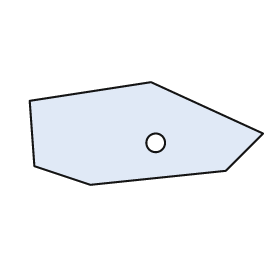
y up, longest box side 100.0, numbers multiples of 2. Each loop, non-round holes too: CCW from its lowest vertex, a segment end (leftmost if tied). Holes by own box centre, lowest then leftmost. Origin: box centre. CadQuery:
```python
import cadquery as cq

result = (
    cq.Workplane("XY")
    .moveTo(-24.0, -22.0)
    .lineTo(34.0, -16.0)
    .lineTo(50.0, 0.0)
    .lineTo(2.0, 22.0)
    .lineTo(-50.0, 14.0)
    .lineTo(-48.0, -14.0)
    .close()
    .moveTo(4.0, -4.0)
    .circle(4.0)
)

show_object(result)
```